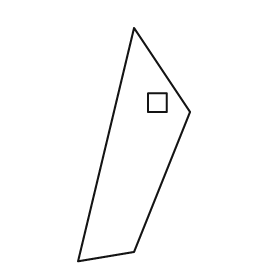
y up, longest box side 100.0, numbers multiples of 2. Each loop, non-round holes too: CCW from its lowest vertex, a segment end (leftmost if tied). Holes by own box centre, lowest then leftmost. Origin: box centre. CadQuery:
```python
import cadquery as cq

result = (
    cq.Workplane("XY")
    .moveTo(-24.0, -50.0)
    .lineTo(0.0, -46.0)
    .lineTo(24.0, 14.0)
    .lineTo(0.0, 50.0)
    .close()
    .moveTo(6.0, 14.0)
    .lineTo(14.0, 14.0)
    .lineTo(14.0, 22.0)
    .lineTo(6.0, 22.0)
    .close()
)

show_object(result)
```